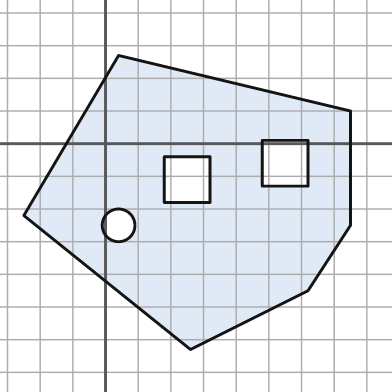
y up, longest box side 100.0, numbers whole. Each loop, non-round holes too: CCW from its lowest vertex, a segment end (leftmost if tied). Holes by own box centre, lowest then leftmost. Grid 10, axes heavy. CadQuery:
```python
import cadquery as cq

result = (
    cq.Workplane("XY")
    .moveTo(26.0, -63.0)
    .lineTo(62.0, -45.0)
    .lineTo(75.0, -25.0)
    .lineTo(75.0, 10.0)
    .lineTo(4.0, 27.0)
    .lineTo(-25.0, -22.0)
    .close()
    .moveTo(4.0, -25.0)
    .circle(5.0)
    .moveTo(18.0, -18.0)
    .lineTo(32.0, -18.0)
    .lineTo(32.0, -4.0)
    .lineTo(18.0, -4.0)
    .close()
    .moveTo(48.0, -13.0)
    .lineTo(62.0, -13.0)
    .lineTo(62.0, 1.0)
    .lineTo(48.0, 1.0)
    .close()
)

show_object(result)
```